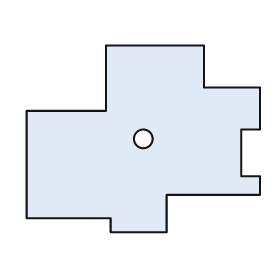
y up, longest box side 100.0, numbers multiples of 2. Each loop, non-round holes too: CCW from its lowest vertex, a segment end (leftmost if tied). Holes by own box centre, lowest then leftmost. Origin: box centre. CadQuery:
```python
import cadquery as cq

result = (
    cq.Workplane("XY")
    .moveTo(-14.0, -40.0)
    .lineTo(10.0, -40.0)
    .lineTo(10.0, -24.0)
    .lineTo(50.0, -24.0)
    .lineTo(50.0, -16.0)
    .lineTo(42.0, -16.0)
    .lineTo(42.0, 4.0)
    .lineTo(50.0, 4.0)
    .lineTo(50.0, 22.0)
    .lineTo(26.0, 22.0)
    .lineTo(26.0, 40.0)
    .lineTo(-16.0, 40.0)
    .lineTo(-16.0, 12.0)
    .lineTo(-50.0, 12.0)
    .lineTo(-50.0, -34.0)
    .lineTo(-14.0, -34.0)
    .close()
    .moveTo(0.0, 0.0)
    .circle(4.0)
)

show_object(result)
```